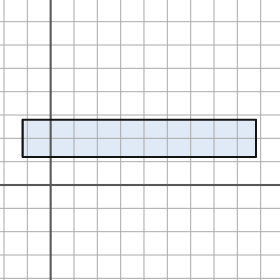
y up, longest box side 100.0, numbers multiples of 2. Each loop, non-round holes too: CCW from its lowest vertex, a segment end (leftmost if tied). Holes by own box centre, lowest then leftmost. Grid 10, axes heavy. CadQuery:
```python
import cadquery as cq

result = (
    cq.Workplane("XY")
    .moveTo(-12.0, 12.0)
    .lineTo(88.0, 12.0)
    .lineTo(88.0, 28.0)
    .lineTo(-12.0, 28.0)
    .close()
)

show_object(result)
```